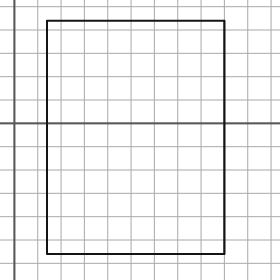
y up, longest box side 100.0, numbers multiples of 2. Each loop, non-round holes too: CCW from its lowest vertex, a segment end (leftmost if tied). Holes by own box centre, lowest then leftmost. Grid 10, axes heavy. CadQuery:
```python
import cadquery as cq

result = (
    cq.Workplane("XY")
    .moveTo(14.0, -56.0)
    .lineTo(90.0, -56.0)
    .lineTo(90.0, 44.0)
    .lineTo(14.0, 44.0)
    .close()
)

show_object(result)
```